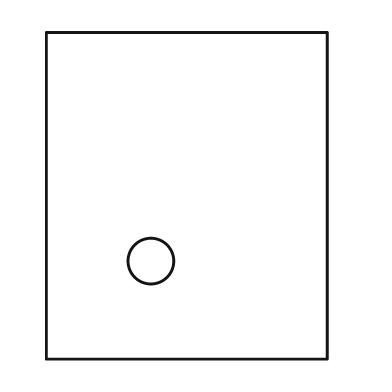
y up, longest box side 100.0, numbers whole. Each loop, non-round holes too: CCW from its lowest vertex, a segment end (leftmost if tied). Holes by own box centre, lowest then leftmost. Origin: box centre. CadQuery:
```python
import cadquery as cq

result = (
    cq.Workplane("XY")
    .moveTo(-43.0, -50.0)
    .lineTo(43.0, -50.0)
    .lineTo(43.0, 50.0)
    .lineTo(-43.0, 50.0)
    .close()
    .moveTo(-11.0, -20.0)
    .circle(7.0)
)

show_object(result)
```